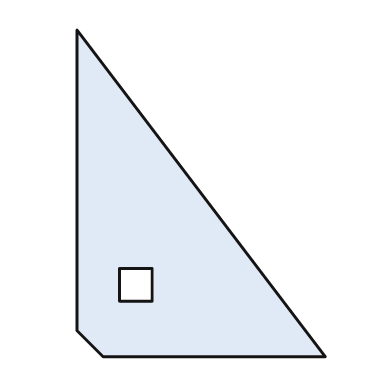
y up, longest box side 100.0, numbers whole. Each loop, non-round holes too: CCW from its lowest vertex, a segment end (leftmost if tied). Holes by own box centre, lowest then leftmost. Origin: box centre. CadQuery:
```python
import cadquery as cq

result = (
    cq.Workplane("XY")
    .moveTo(-30.0, -50.0)
    .lineTo(38.0, -50.0)
    .lineTo(-38.0, 50.0)
    .lineTo(-38.0, -42.0)
    .close()
    .moveTo(-25.0, -33.0)
    .lineTo(-15.0, -33.0)
    .lineTo(-15.0, -23.0)
    .lineTo(-25.0, -23.0)
    .close()
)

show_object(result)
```